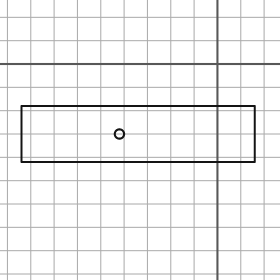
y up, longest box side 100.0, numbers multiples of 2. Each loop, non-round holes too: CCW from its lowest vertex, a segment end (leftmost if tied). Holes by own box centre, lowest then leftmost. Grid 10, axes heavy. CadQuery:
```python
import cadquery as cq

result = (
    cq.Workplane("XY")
    .moveTo(-84.0, -42.0)
    .lineTo(16.0, -42.0)
    .lineTo(16.0, -18.0)
    .lineTo(-84.0, -18.0)
    .close()
    .moveTo(-42.0, -30.0)
    .circle(2.0)
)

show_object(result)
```